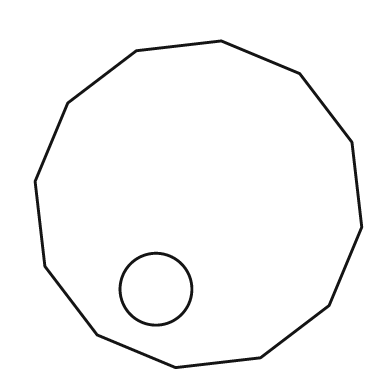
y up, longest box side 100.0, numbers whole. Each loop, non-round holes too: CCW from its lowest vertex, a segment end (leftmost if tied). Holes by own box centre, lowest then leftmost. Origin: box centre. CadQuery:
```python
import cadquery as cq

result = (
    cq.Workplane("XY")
    .moveTo(-7.0, -50.0)
    .lineTo(19.0, -47.0)
    .lineTo(40.0, -31.0)
    .lineTo(50.0, -7.0)
    .lineTo(47.0, 19.0)
    .lineTo(31.0, 40.0)
    .lineTo(7.0, 50.0)
    .lineTo(-19.0, 47.0)
    .lineTo(-40.0, 31.0)
    .lineTo(-50.0, 7.0)
    .lineTo(-47.0, -19.0)
    .lineTo(-31.0, -40.0)
    .close()
    .moveTo(-13.0, -26.0)
    .circle(11.0)
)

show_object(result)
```